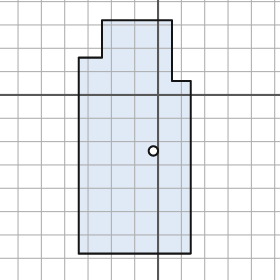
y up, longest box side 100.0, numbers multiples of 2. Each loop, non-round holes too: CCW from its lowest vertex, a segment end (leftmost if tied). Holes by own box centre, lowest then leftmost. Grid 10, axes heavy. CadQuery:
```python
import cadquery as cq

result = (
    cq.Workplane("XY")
    .moveTo(-34.0, -68.0)
    .lineTo(14.0, -68.0)
    .lineTo(14.0, 6.0)
    .lineTo(6.0, 6.0)
    .lineTo(6.0, 32.0)
    .lineTo(-24.0, 32.0)
    .lineTo(-24.0, 16.0)
    .lineTo(-34.0, 16.0)
    .close()
    .moveTo(-2.0, -24.0)
    .circle(2.0)
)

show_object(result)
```